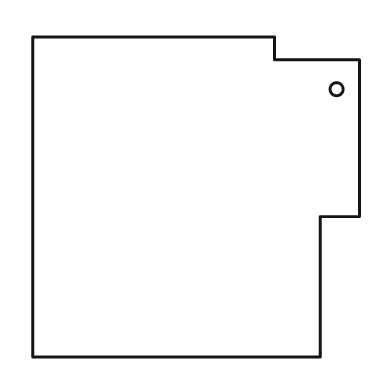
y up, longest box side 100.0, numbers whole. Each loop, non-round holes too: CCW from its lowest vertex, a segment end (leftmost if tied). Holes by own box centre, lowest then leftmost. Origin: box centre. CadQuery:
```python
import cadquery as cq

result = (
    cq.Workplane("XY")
    .moveTo(-50.0, -49.0)
    .lineTo(38.0, -49.0)
    .lineTo(38.0, -6.0)
    .lineTo(50.0, -6.0)
    .lineTo(50.0, 42.0)
    .lineTo(24.0, 42.0)
    .lineTo(24.0, 49.0)
    .lineTo(-50.0, 49.0)
    .close()
    .moveTo(43.0, 33.0)
    .circle(2.0)
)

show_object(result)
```